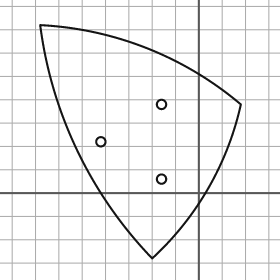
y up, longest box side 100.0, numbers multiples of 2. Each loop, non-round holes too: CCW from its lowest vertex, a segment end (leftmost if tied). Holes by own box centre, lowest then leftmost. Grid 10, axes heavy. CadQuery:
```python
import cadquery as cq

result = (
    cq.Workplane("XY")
    .moveTo(-20.0, -28.0)
    .threePointArc((4.0, 2.0), (18.0, 38.0))
    .threePointArc((-22.0, 62.0), (-68.0, 72.0))
    .threePointArc((-52.0, 18.0), (-20.0, -28.0))
    .close()
    .moveTo(-16.0, 6.0)
    .circle(2.0)
    .moveTo(-42.0, 22.0)
    .circle(2.0)
    .moveTo(-16.0, 38.0)
    .circle(2.0)
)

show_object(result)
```